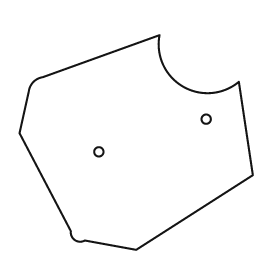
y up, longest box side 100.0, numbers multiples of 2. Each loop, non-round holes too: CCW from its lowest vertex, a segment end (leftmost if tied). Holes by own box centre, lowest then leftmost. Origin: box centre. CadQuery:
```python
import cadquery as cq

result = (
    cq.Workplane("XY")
    .moveTo(0.0, -46.0)
    .lineTo(50.0, -14.0)
    .lineTo(44.0, 26.0)
    .threePointArc((20.0, 24.0), (10.0, 46.0))
    .lineTo(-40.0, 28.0)
    .threePointArc((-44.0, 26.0), (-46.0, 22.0))
    .lineTo(-50.0, 4.0)
    .lineTo(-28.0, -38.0)
    .threePointArc((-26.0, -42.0), (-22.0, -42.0))
    .close()
    .moveTo(-16.0, -4.0)
    .circle(2.0)
    .moveTo(30.0, 10.0)
    .circle(2.0)
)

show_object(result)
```